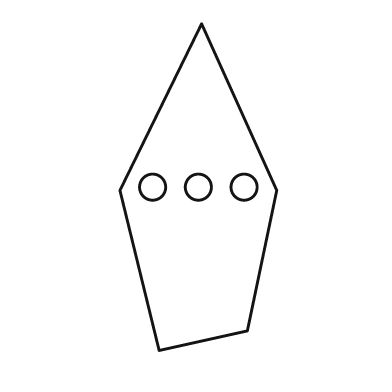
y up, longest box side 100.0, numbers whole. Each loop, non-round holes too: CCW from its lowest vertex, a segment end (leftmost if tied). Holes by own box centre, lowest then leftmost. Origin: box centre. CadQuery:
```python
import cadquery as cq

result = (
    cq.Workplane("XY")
    .moveTo(-12.0, -50.0)
    .lineTo(15.0, -44.0)
    .lineTo(24.0, -1.0)
    .lineTo(1.0, 50.0)
    .lineTo(-24.0, -1.0)
    .close()
    .moveTo(-14.0, 0.0)
    .circle(4.0)
    .moveTo(0.0, 0.0)
    .circle(4.0)
    .moveTo(14.0, 0.0)
    .circle(4.0)
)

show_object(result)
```